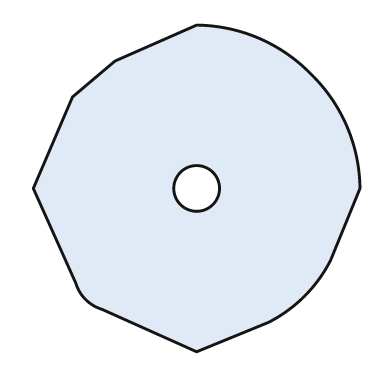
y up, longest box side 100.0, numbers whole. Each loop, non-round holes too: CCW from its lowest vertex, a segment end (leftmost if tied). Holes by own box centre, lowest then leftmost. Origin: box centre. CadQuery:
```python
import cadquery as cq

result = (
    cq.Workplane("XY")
    .moveTo(0.0, -50.0)
    .lineTo(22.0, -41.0)
    .threePointArc((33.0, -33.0), (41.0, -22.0))
    .lineTo(50.0, 0.0)
    .threePointArc((46.0, 19.0), (35.0, 35.0))
    .threePointArc((19.0, 46.0), (0.0, 50.0))
    .lineTo(-25.0, 39.0)
    .lineTo(-38.0, 28.0)
    .lineTo(-50.0, 0.0)
    .lineTo(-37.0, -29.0)
    .threePointArc((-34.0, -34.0), (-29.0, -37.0))
    .close()
    .moveTo(0.0, 0.0)
    .circle(7.0)
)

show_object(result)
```